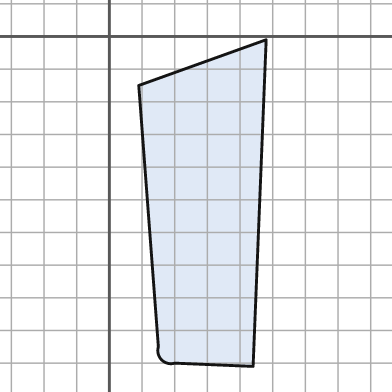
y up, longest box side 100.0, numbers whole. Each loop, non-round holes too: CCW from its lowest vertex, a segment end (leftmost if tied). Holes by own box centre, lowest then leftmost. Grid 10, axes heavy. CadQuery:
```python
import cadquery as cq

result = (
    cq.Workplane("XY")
    .moveTo(44.0, -101.0)
    .lineTo(48.0, -1.0)
    .lineTo(9.0, -15.0)
    .lineTo(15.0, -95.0)
    .threePointArc((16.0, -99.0), (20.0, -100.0))
    .close()
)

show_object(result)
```